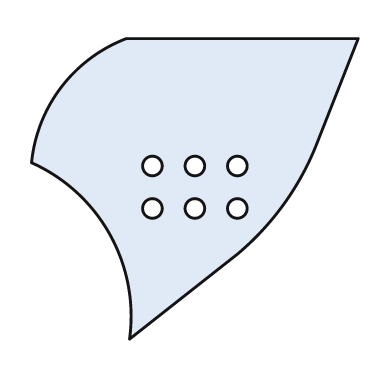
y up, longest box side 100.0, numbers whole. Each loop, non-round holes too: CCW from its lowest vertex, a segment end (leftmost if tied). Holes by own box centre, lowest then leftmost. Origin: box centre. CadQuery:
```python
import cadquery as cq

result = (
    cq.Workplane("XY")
    .moveTo(-20.0, -46.0)
    .lineTo(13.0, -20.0)
    .threePointArc((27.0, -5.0), (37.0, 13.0))
    .lineTo(50.0, 46.0)
    .lineTo(-21.0, 46.0)
    .threePointArc((-41.0, 31.0), (-50.0, 8.0))
    .threePointArc((-26.0, -14.0), (-20.0, -46.0))
    .close()
    .moveTo(-13.0, -6.0)
    .circle(3.0)
    .moveTo(0.0, -6.0)
    .circle(3.0)
    .moveTo(13.0, -6.0)
    .circle(3.0)
    .moveTo(-13.0, 7.0)
    .circle(3.0)
    .moveTo(0.0, 7.0)
    .circle(3.0)
    .moveTo(13.0, 7.0)
    .circle(3.0)
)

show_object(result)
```